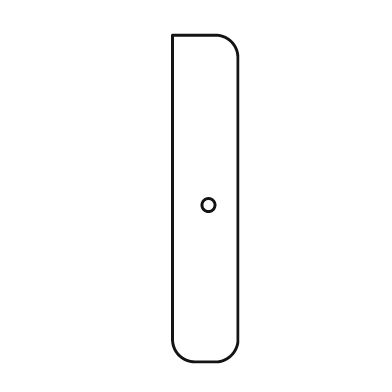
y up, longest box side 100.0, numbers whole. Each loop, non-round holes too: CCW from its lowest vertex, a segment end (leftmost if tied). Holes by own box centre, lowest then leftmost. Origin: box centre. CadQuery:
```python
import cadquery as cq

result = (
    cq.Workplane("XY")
    .moveTo(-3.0, -50.0)
    .lineTo(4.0, -50.0)
    .threePointArc((8.0, -48.0), (10.0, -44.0))
    .lineTo(10.0, 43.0)
    .threePointArc((8.0, 48.0), (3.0, 50.0))
    .lineTo(-10.0, 50.0)
    .lineTo(-10.0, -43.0)
    .threePointArc((-8.0, -48.0), (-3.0, -50.0))
    .close()
    .moveTo(1.0, -2.0)
    .circle(2.0)
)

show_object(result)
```